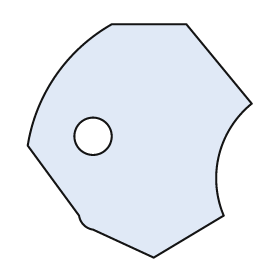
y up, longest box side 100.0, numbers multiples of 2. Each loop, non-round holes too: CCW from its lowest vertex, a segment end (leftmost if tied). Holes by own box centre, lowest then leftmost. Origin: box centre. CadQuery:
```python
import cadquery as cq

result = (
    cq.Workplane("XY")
    .moveTo(6.0, -50.0)
    .lineTo(36.0, -32.0)
    .threePointArc((34.0, -6.0), (48.0, 16.0))
    .lineTo(20.0, 50.0)
    .lineTo(-12.0, 50.0)
    .threePointArc((-36.0, 28.0), (-48.0, -2.0))
    .lineTo(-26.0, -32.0)
    .threePointArc((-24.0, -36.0), (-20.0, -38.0))
    .close()
    .moveTo(-20.0, 2.0)
    .circle(8.0)
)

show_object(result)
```